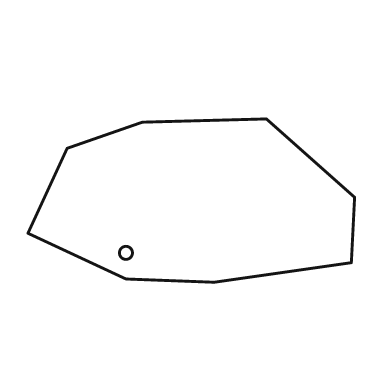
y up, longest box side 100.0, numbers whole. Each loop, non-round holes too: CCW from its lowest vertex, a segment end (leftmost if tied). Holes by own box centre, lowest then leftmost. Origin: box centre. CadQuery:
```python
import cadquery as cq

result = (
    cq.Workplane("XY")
    .moveTo(7.0, -25.0)
    .lineTo(49.0, -19.0)
    .lineTo(50.0, 1.0)
    .lineTo(23.0, 25.0)
    .lineTo(-15.0, 24.0)
    .lineTo(-38.0, 16.0)
    .lineTo(-50.0, -10.0)
    .lineTo(-20.0, -24.0)
    .close()
    .moveTo(-20.0, -16.0)
    .circle(2.0)
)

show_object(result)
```